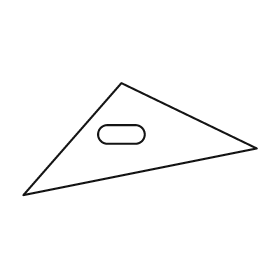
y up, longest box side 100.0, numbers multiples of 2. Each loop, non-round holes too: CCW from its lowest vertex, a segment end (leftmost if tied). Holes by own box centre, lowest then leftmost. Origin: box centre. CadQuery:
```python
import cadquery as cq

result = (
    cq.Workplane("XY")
    .moveTo(-50.0, -24.0)
    .lineTo(50.0, -4.0)
    .lineTo(-8.0, 24.0)
    .close()
    .moveTo(-14.0, -2.0)
    .lineTo(-2.0, -2.0)
    .threePointArc((2.0, 2.0), (-2.0, 6.0))
    .lineTo(-14.0, 6.0)
    .threePointArc((-18.0, 2.0), (-14.0, -2.0))
    .close()
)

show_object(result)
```